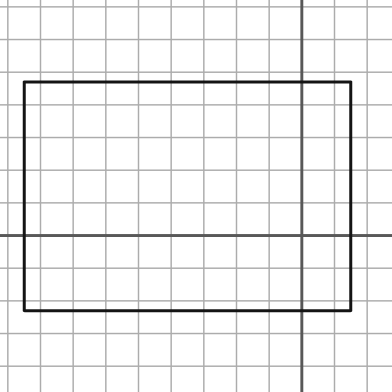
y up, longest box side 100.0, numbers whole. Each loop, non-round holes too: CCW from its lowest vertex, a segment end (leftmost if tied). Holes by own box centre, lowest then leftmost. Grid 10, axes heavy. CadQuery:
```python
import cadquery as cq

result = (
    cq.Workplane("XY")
    .moveTo(-85.0, -23.0)
    .lineTo(15.0, -23.0)
    .lineTo(15.0, 47.0)
    .lineTo(-85.0, 47.0)
    .close()
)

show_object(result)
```